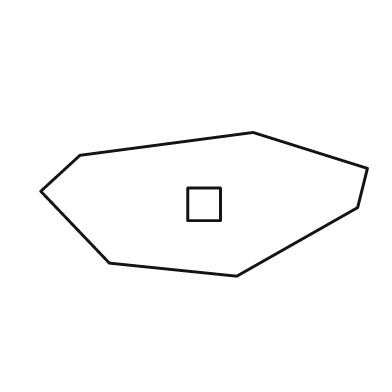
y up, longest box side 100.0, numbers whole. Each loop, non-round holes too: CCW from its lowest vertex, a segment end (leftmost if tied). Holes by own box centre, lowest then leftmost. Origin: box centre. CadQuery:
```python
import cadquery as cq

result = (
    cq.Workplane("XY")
    .moveTo(10.0, -22.0)
    .lineTo(47.0, -1.0)
    .lineTo(50.0, 11.0)
    .lineTo(15.0, 22.0)
    .lineTo(-38.0, 15.0)
    .lineTo(-50.0, 4.0)
    .lineTo(-29.0, -18.0)
    .close()
    .moveTo(-5.0, -5.0)
    .lineTo(5.0, -5.0)
    .lineTo(5.0, 5.0)
    .lineTo(-5.0, 5.0)
    .close()
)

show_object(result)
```